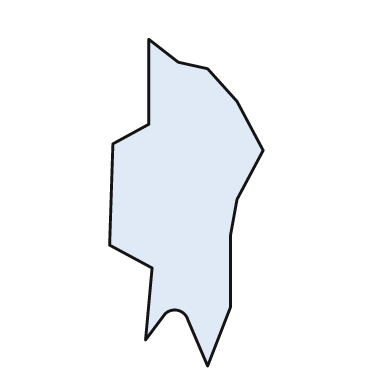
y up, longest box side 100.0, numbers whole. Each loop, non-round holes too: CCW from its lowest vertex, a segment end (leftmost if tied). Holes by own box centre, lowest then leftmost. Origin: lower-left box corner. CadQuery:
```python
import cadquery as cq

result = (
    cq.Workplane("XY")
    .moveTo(30.0, 0.0)
    .lineTo(37.0, 18.0)
    .lineTo(37.0, 40.0)
    .lineTo(39.0, 51.0)
    .lineTo(47.0, 66.0)
    .lineTo(39.0, 81.0)
    .lineTo(30.0, 91.0)
    .lineTo(21.0, 93.0)
    .lineTo(12.0, 100.0)
    .lineTo(12.0, 74.0)
    .lineTo(1.0, 68.0)
    .lineTo(0.0, 37.0)
    .lineTo(13.0, 30.0)
    .lineTo(11.0, 8.0)
    .lineTo(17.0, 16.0)
    .threePointArc((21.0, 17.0), (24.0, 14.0))
    .close()
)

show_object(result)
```